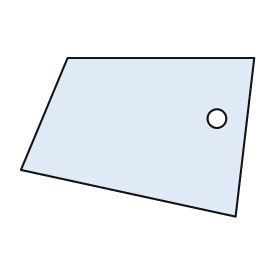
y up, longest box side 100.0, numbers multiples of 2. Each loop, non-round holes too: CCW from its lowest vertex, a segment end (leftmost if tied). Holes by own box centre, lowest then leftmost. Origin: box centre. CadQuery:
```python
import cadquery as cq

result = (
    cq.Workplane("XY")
    .moveTo(42.0, -34.0)
    .lineTo(50.0, 34.0)
    .lineTo(-30.0, 34.0)
    .lineTo(-50.0, -14.0)
    .close()
    .moveTo(34.0, 8.0)
    .circle(4.0)
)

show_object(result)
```